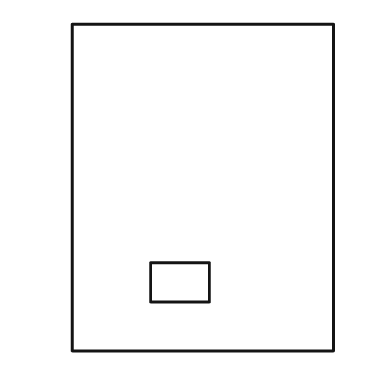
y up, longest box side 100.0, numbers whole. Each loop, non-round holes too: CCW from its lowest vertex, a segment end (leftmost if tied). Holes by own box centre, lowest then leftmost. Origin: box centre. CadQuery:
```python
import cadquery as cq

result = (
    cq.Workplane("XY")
    .moveTo(-40.0, -50.0)
    .lineTo(40.0, -50.0)
    .lineTo(40.0, 50.0)
    .lineTo(-40.0, 50.0)
    .close()
    .moveTo(-16.0, -35.0)
    .lineTo(2.0, -35.0)
    .lineTo(2.0, -23.0)
    .lineTo(-16.0, -23.0)
    .close()
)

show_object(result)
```